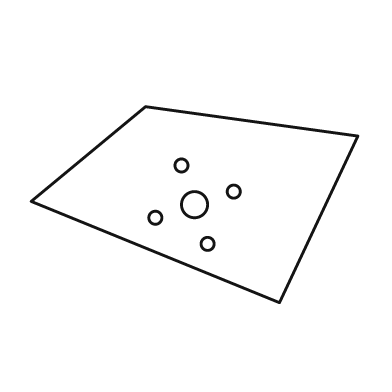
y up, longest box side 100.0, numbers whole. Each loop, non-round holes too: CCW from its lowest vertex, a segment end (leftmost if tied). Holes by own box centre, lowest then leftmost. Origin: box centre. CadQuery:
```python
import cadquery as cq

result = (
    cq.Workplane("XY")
    .moveTo(26.0, -30.0)
    .lineTo(50.0, 21.0)
    .lineTo(-15.0, 30.0)
    .lineTo(-50.0, 1.0)
    .close()
    .moveTo(4.0, -12.0)
    .circle(2.0)
    .moveTo(-12.0, -4.0)
    .circle(2.0)
    .moveTo(0.0, 0.0)
    .circle(4.0)
    .moveTo(12.0, 4.0)
    .circle(2.0)
    .moveTo(-4.0, 12.0)
    .circle(2.0)
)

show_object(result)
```